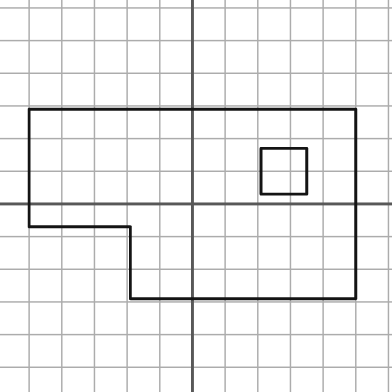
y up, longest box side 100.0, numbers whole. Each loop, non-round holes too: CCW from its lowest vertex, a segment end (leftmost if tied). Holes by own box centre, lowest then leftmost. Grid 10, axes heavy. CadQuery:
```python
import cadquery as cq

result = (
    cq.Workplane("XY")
    .moveTo(-19.0, -29.0)
    .lineTo(50.0, -29.0)
    .lineTo(50.0, 29.0)
    .lineTo(-50.0, 29.0)
    .lineTo(-50.0, -7.0)
    .lineTo(-19.0, -7.0)
    .close()
    .moveTo(21.0, 3.0)
    .lineTo(35.0, 3.0)
    .lineTo(35.0, 17.0)
    .lineTo(21.0, 17.0)
    .close()
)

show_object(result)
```